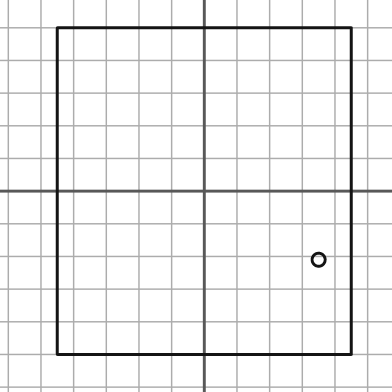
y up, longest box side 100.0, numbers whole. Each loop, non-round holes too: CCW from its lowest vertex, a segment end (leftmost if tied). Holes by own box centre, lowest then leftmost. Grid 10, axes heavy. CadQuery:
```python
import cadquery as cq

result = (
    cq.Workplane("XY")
    .moveTo(-45.0, -50.0)
    .lineTo(45.0, -50.0)
    .lineTo(45.0, 50.0)
    .lineTo(-45.0, 50.0)
    .close()
    .moveTo(35.0, -21.0)
    .circle(2.0)
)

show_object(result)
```